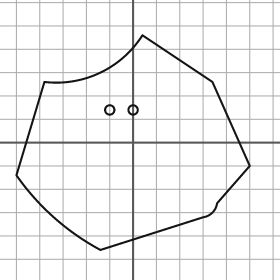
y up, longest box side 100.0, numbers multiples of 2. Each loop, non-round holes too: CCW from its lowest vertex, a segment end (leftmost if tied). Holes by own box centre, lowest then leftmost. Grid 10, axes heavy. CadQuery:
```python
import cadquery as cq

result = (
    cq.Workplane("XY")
    .moveTo(-14.0, -46.0)
    .lineTo(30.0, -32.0)
    .threePointArc((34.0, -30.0), (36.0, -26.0))
    .lineTo(50.0, -10.0)
    .lineTo(34.0, 26.0)
    .lineTo(4.0, 46.0)
    .threePointArc((-14.0, 30.0), (-38.0, 26.0))
    .lineTo(-50.0, -14.0)
    .threePointArc((-34.0, -32.0), (-14.0, -46.0))
    .close()
    .moveTo(-10.0, 14.0)
    .circle(2.0)
    .moveTo(0.0, 14.0)
    .circle(2.0)
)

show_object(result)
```